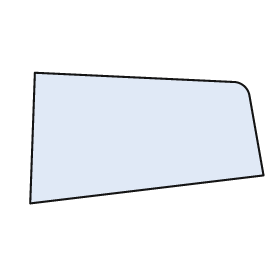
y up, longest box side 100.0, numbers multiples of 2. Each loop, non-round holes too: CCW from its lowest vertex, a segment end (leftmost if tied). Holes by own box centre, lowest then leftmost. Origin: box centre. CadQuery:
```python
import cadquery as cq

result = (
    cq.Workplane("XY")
    .moveTo(-50.0, -28.0)
    .lineTo(50.0, -16.0)
    .lineTo(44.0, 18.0)
    .threePointArc((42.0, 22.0), (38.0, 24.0))
    .lineTo(-48.0, 28.0)
    .close()
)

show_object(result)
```